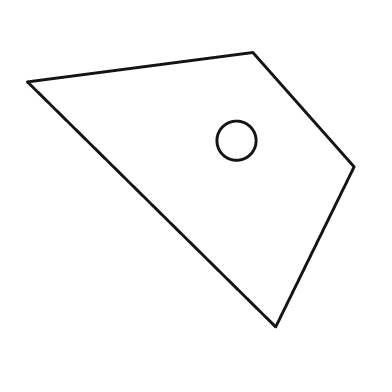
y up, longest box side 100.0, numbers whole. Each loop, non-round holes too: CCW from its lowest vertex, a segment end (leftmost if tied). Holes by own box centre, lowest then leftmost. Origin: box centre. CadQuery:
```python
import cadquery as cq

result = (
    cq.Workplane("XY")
    .moveTo(26.0, -42.0)
    .lineTo(50.0, 7.0)
    .lineTo(19.0, 42.0)
    .lineTo(-50.0, 33.0)
    .close()
    .moveTo(14.0, 15.0)
    .circle(6.0)
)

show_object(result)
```